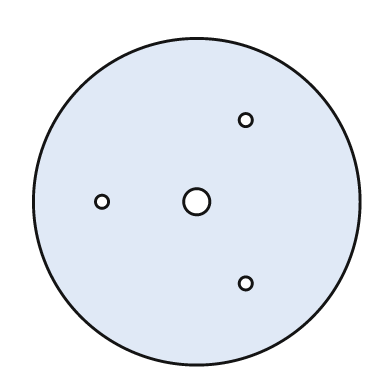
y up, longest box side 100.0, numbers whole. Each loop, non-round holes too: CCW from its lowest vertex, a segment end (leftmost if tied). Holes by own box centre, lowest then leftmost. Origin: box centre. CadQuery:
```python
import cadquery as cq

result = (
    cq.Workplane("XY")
    .moveTo(0.0, 0.0)
    .circle(50.0)
    .moveTo(15.0, -25.0)
    .circle(2.0)
    .moveTo(-29.0, 0.0)
    .circle(2.0)
    .moveTo(0.0, 0.0)
    .circle(4.0)
    .moveTo(15.0, 25.0)
    .circle(2.0)
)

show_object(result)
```